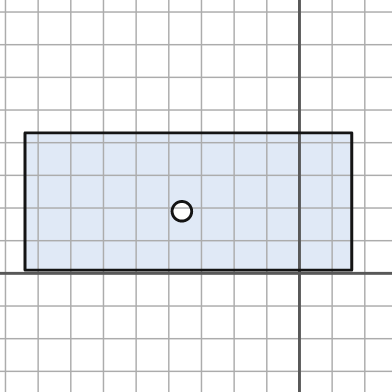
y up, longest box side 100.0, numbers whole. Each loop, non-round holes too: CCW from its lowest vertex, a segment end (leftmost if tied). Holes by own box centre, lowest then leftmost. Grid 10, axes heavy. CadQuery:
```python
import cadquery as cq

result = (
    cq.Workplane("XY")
    .moveTo(-84.0, 1.0)
    .lineTo(16.0, 1.0)
    .lineTo(16.0, 43.0)
    .lineTo(-84.0, 43.0)
    .close()
    .moveTo(-36.0, 19.0)
    .circle(3.0)
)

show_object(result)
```